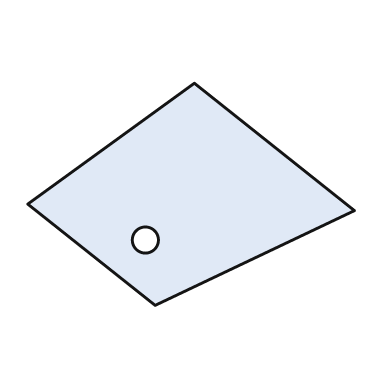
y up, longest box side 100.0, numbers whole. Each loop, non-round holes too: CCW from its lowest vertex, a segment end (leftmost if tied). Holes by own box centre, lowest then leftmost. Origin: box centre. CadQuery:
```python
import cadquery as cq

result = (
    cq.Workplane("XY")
    .moveTo(-11.0, -34.0)
    .lineTo(50.0, -5.0)
    .lineTo(1.0, 34.0)
    .lineTo(-50.0, -3.0)
    .close()
    .moveTo(-14.0, -14.0)
    .circle(4.0)
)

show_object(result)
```